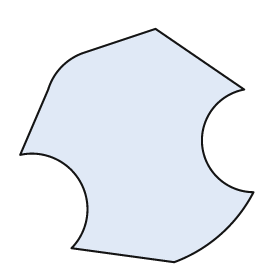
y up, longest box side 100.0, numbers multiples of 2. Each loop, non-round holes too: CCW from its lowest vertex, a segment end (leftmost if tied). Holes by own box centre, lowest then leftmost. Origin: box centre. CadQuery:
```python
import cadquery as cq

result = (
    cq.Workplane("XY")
    .moveTo(16.0, -50.0)
    .threePointArc((36.0, -38.0), (50.0, -20.0))
    .threePointArc((28.0, 0.0), (46.0, 24.0))
    .lineTo(8.0, 50.0)
    .lineTo(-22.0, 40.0)
    .threePointArc((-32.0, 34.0), (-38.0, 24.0))
    .lineTo(-50.0, -4.0)
    .threePointArc((-24.0, -16.0), (-28.0, -44.0))
    .close()
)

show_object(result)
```